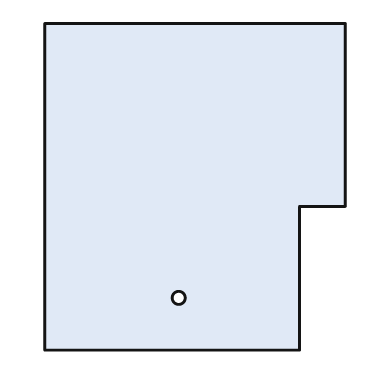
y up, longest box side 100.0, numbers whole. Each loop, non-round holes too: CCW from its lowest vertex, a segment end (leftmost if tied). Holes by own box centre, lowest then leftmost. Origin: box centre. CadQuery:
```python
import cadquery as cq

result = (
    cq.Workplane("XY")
    .moveTo(-46.0, -50.0)
    .lineTo(32.0, -50.0)
    .lineTo(32.0, -6.0)
    .lineTo(46.0, -6.0)
    .lineTo(46.0, 50.0)
    .lineTo(-46.0, 50.0)
    .close()
    .moveTo(-5.0, -34.0)
    .circle(2.0)
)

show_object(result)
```